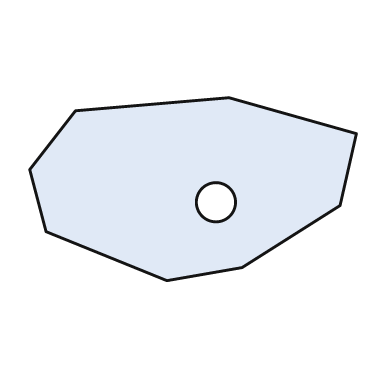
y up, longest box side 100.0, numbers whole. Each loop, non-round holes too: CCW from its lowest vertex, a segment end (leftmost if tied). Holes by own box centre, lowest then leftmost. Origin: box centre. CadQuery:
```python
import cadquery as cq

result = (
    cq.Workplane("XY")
    .moveTo(-8.0, -28.0)
    .lineTo(15.0, -24.0)
    .lineTo(45.0, -5.0)
    .lineTo(50.0, 17.0)
    .lineTo(11.0, 28.0)
    .lineTo(-36.0, 24.0)
    .lineTo(-50.0, 6.0)
    .lineTo(-45.0, -13.0)
    .close()
    .moveTo(7.0, -4.0)
    .circle(6.0)
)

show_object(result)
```